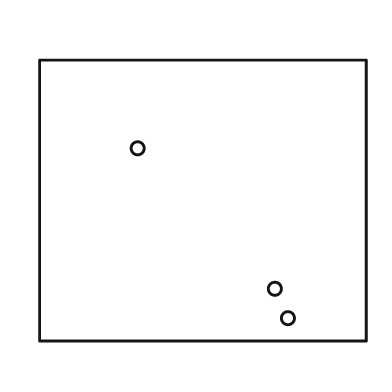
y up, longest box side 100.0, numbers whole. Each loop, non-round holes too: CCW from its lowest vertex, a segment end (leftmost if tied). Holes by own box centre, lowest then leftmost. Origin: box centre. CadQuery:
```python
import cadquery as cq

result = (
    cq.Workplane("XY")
    .moveTo(-50.0, -43.0)
    .lineTo(50.0, -43.0)
    .lineTo(50.0, 43.0)
    .lineTo(-50.0, 43.0)
    .close()
    .moveTo(26.0, -36.0)
    .circle(2.0)
    .moveTo(22.0, -27.0)
    .circle(2.0)
    .moveTo(-20.0, 16.0)
    .circle(2.0)
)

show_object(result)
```